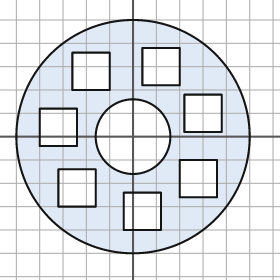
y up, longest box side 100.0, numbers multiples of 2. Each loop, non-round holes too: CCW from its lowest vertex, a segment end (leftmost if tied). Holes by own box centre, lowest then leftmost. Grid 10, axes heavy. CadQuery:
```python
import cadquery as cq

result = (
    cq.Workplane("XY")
    .moveTo(0.0, 0.0)
    .circle(50.0)
    .moveTo(-4.0, -40.0)
    .lineTo(12.0, -40.0)
    .lineTo(12.0, -24.0)
    .lineTo(-4.0, -24.0)
    .close()
    .moveTo(-32.0, -30.0)
    .lineTo(-16.0, -30.0)
    .lineTo(-16.0, -14.0)
    .lineTo(-32.0, -14.0)
    .close()
    .moveTo(20.0, -26.0)
    .lineTo(36.0, -26.0)
    .lineTo(36.0, -10.0)
    .lineTo(20.0, -10.0)
    .close()
    .moveTo(0.0, 0.0)
    .circle(16.0)
    .moveTo(-40.0, -4.0)
    .lineTo(-24.0, -4.0)
    .lineTo(-24.0, 12.0)
    .lineTo(-40.0, 12.0)
    .close()
    .moveTo(22.0, 2.0)
    .lineTo(38.0, 2.0)
    .lineTo(38.0, 18.0)
    .lineTo(22.0, 18.0)
    .close()
    .moveTo(-26.0, 20.0)
    .lineTo(-10.0, 20.0)
    .lineTo(-10.0, 36.0)
    .lineTo(-26.0, 36.0)
    .close()
    .moveTo(4.0, 22.0)
    .lineTo(20.0, 22.0)
    .lineTo(20.0, 38.0)
    .lineTo(4.0, 38.0)
    .close()
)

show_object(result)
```